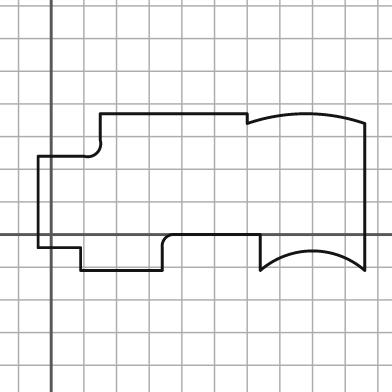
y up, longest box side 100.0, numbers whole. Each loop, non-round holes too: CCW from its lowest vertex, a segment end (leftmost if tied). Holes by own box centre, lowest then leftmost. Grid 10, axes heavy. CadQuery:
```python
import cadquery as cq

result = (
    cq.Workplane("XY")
    .moveTo(9.0, -11.0)
    .lineTo(34.0, -11.0)
    .lineTo(34.0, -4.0)
    .threePointArc((35.0, -1.0), (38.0, 0.0))
    .lineTo(64.0, 0.0)
    .lineTo(64.0, -11.0)
    .threePointArc((80.0, -5.0), (96.0, -11.0))
    .lineTo(96.0, 34.0)
    .threePointArc((78.0, 37.0), (60.0, 34.0))
    .lineTo(60.0, 37.0)
    .lineTo(15.0, 37.0)
    .lineTo(15.0, 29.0)
    .threePointArc((14.0, 25.0), (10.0, 24.0))
    .lineTo(-4.0, 24.0)
    .lineTo(-4.0, -4.0)
    .lineTo(9.0, -4.0)
    .close()
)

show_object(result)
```